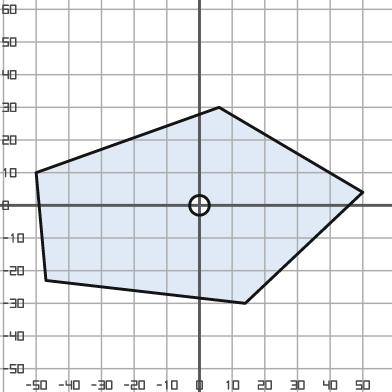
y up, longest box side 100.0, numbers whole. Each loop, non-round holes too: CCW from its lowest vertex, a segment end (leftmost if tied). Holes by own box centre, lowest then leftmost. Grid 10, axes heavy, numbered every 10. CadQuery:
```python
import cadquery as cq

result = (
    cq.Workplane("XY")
    .moveTo(14.0, -30.0)
    .lineTo(50.0, 4.0)
    .lineTo(6.0, 30.0)
    .lineTo(-50.0, 10.0)
    .lineTo(-47.0, -23.0)
    .close()
    .moveTo(0.0, 0.0)
    .circle(3.0)
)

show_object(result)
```